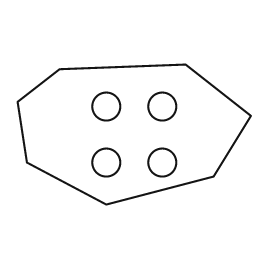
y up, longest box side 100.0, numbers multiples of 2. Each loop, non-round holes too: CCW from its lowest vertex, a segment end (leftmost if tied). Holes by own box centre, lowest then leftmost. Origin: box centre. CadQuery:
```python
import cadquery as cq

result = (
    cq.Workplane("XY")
    .moveTo(-12.0, -30.0)
    .lineTo(34.0, -18.0)
    .lineTo(50.0, 8.0)
    .lineTo(22.0, 30.0)
    .lineTo(-32.0, 28.0)
    .lineTo(-50.0, 14.0)
    .lineTo(-46.0, -12.0)
    .close()
    .moveTo(-12.0, -12.0)
    .circle(6.0)
    .moveTo(12.0, -12.0)
    .circle(6.0)
    .moveTo(-12.0, 12.0)
    .circle(6.0)
    .moveTo(12.0, 12.0)
    .circle(6.0)
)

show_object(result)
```